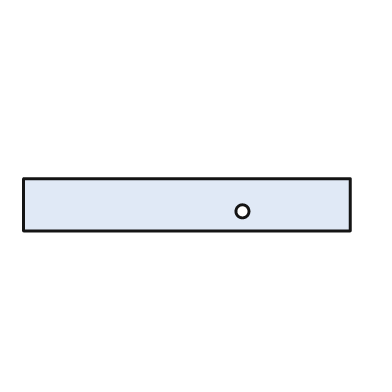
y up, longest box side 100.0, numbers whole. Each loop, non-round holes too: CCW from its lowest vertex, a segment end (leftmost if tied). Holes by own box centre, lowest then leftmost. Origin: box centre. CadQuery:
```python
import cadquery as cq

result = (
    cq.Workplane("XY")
    .moveTo(-50.0, -8.0)
    .lineTo(50.0, -8.0)
    .lineTo(50.0, 8.0)
    .lineTo(-50.0, 8.0)
    .close()
    .moveTo(17.0, -2.0)
    .circle(2.0)
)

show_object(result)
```